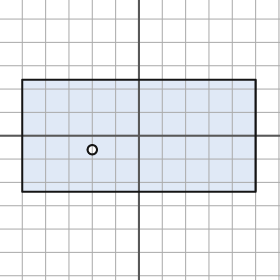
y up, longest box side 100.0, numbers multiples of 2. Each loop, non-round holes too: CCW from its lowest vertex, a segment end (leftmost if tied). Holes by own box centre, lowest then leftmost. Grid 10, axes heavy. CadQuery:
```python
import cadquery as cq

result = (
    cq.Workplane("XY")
    .moveTo(-50.0, -24.0)
    .lineTo(50.0, -24.0)
    .lineTo(50.0, 24.0)
    .lineTo(-50.0, 24.0)
    .close()
    .moveTo(-20.0, -6.0)
    .circle(2.0)
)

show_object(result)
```